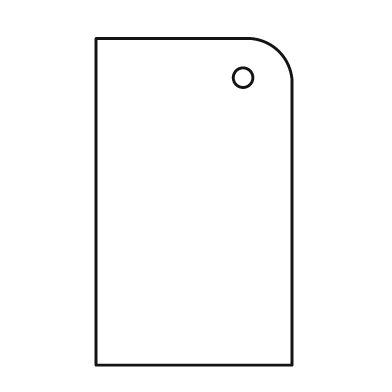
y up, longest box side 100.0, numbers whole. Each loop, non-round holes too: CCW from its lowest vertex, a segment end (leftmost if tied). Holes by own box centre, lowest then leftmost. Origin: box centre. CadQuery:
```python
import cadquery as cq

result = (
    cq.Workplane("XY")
    .moveTo(-30.0, -50.0)
    .lineTo(30.0, -50.0)
    .lineTo(30.0, 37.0)
    .threePointArc((26.0, 46.0), (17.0, 50.0))
    .lineTo(-30.0, 50.0)
    .close()
    .moveTo(15.0, 38.0)
    .circle(3.0)
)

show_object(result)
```